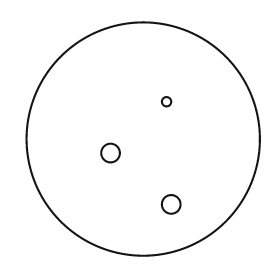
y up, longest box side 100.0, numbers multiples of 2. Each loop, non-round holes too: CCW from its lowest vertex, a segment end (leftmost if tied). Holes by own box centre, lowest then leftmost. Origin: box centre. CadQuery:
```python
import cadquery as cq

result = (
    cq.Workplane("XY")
    .moveTo(0.0, 0.0)
    .circle(50.0)
    .moveTo(12.0, -28.0)
    .circle(4.0)
    .moveTo(-14.0, -6.0)
    .circle(4.0)
    .moveTo(10.0, 16.0)
    .circle(2.0)
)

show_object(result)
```